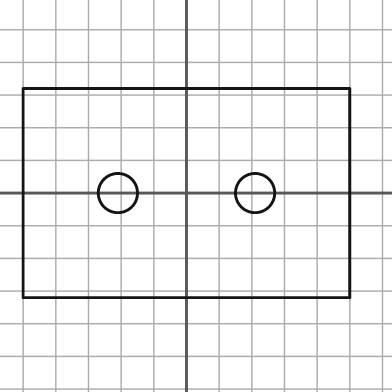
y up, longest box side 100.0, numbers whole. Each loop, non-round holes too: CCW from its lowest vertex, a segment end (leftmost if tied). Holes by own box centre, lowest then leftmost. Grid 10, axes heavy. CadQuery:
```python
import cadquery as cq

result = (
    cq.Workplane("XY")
    .moveTo(-50.0, -32.0)
    .lineTo(50.0, -32.0)
    .lineTo(50.0, 32.0)
    .lineTo(-50.0, 32.0)
    .close()
    .moveTo(-21.0, 0.0)
    .circle(6.0)
    .moveTo(21.0, 0.0)
    .circle(6.0)
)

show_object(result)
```